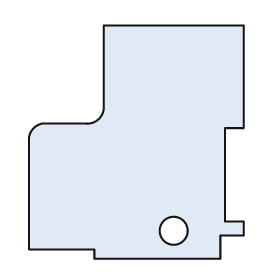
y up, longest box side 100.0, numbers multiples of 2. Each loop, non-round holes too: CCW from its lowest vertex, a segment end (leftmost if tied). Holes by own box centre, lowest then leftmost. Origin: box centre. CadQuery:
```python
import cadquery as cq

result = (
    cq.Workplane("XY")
    .moveTo(-18.0, -50.0)
    .lineTo(36.0, -50.0)
    .lineTo(36.0, -40.0)
    .lineTo(46.0, -40.0)
    .lineTo(46.0, -34.0)
    .lineTo(38.0, -34.0)
    .lineTo(38.0, 6.0)
    .lineTo(46.0, 6.0)
    .lineTo(46.0, 50.0)
    .lineTo(-14.0, 50.0)
    .lineTo(-14.0, 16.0)
    .threePointArc((-16.0, 10.0), (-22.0, 8.0))
    .lineTo(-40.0, 8.0)
    .threePointArc((-44.0, 6.0), (-46.0, 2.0))
    .lineTo(-46.0, -46.0)
    .lineTo(-18.0, -46.0)
    .close()
    .moveTo(16.0, -38.0)
    .circle(6.0)
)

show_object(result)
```